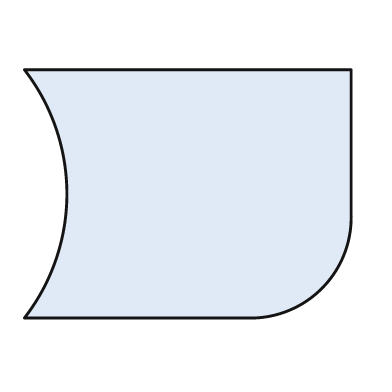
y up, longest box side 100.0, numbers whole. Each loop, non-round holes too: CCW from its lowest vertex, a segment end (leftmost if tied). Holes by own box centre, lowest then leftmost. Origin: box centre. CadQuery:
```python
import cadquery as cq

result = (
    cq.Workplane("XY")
    .moveTo(-50.0, -38.0)
    .lineTo(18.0, -38.0)
    .threePointArc((41.0, -29.0), (50.0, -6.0))
    .lineTo(50.0, 38.0)
    .lineTo(-50.0, 38.0)
    .threePointArc((-37.0, 0.0), (-50.0, -38.0))
    .close()
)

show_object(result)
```